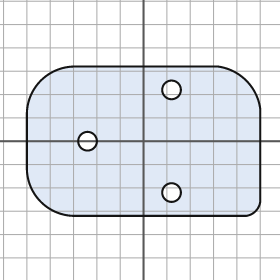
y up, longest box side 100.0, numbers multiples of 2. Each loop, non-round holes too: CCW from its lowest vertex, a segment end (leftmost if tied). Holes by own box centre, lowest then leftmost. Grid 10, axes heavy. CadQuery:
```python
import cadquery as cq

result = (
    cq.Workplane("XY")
    .moveTo(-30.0, -32.0)
    .lineTo(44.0, -32.0)
    .threePointArc((48.0, -30.0), (50.0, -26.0))
    .lineTo(50.0, 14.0)
    .threePointArc((44.0, 26.0), (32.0, 32.0))
    .lineTo(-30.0, 32.0)
    .threePointArc((-44.0, 26.0), (-50.0, 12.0))
    .lineTo(-50.0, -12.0)
    .threePointArc((-44.0, -26.0), (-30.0, -32.0))
    .close()
    .moveTo(12.0, -22.0)
    .circle(4.0)
    .moveTo(-24.0, 0.0)
    .circle(4.0)
    .moveTo(12.0, 22.0)
    .circle(4.0)
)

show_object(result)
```